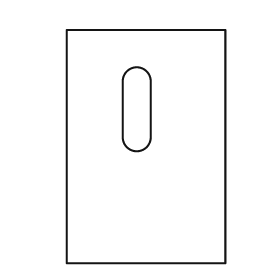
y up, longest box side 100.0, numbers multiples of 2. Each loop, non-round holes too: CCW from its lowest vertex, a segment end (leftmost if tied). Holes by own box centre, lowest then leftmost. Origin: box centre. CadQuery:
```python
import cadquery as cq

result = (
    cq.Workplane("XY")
    .moveTo(-34.0, -50.0)
    .lineTo(34.0, -50.0)
    .lineTo(34.0, 50.0)
    .lineTo(-34.0, 50.0)
    .close()
    .moveTo(-10.0, 4.0)
    .threePointArc((-4.0, -2.0), (2.0, 4.0))
    .lineTo(2.0, 28.0)
    .threePointArc((-4.0, 34.0), (-10.0, 28.0))
    .close()
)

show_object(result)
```